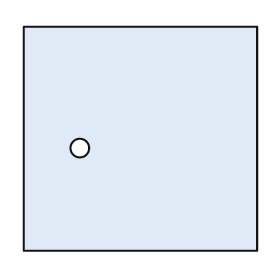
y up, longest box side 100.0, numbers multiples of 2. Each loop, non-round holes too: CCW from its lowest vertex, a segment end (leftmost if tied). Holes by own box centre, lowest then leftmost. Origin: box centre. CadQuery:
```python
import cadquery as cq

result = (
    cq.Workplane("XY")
    .moveTo(-50.0, -48.0)
    .lineTo(50.0, -48.0)
    .lineTo(50.0, 48.0)
    .lineTo(-50.0, 48.0)
    .close()
    .moveTo(-26.0, -4.0)
    .circle(4.0)
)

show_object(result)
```